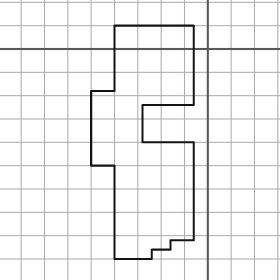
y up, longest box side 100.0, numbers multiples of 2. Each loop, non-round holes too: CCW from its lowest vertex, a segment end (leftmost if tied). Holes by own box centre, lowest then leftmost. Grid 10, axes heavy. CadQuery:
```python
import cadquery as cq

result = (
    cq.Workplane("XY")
    .moveTo(-40.0, -90.0)
    .lineTo(-24.0, -90.0)
    .lineTo(-24.0, -86.0)
    .lineTo(-16.0, -86.0)
    .lineTo(-16.0, -82.0)
    .lineTo(-6.0, -82.0)
    .lineTo(-6.0, -40.0)
    .lineTo(-28.0, -40.0)
    .lineTo(-28.0, -24.0)
    .lineTo(-6.0, -24.0)
    .lineTo(-6.0, 10.0)
    .lineTo(-40.0, 10.0)
    .lineTo(-40.0, -18.0)
    .lineTo(-50.0, -18.0)
    .lineTo(-50.0, -50.0)
    .lineTo(-40.0, -50.0)
    .close()
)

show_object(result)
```